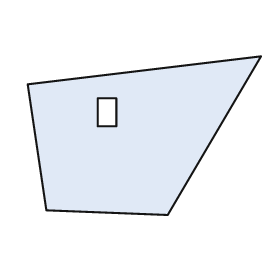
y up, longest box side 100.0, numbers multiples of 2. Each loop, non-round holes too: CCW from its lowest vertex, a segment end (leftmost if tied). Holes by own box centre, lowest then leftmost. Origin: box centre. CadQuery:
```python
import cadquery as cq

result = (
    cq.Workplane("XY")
    .moveTo(10.0, -34.0)
    .lineTo(50.0, 34.0)
    .lineTo(-50.0, 22.0)
    .lineTo(-42.0, -32.0)
    .close()
    .moveTo(-20.0, 4.0)
    .lineTo(-12.0, 4.0)
    .lineTo(-12.0, 16.0)
    .lineTo(-20.0, 16.0)
    .close()
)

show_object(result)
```